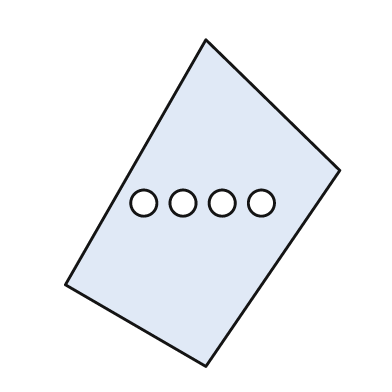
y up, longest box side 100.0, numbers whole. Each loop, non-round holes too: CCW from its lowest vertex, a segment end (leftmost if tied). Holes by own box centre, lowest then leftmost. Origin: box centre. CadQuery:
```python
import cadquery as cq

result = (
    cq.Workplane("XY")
    .moveTo(1.0, -50.0)
    .lineTo(42.0, 10.0)
    .lineTo(1.0, 50.0)
    .lineTo(-42.0, -25.0)
    .close()
    .moveTo(-18.0, 0.0)
    .circle(4.0)
    .moveTo(-6.0, 0.0)
    .circle(4.0)
    .moveTo(6.0, 0.0)
    .circle(4.0)
    .moveTo(18.0, 0.0)
    .circle(4.0)
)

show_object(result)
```